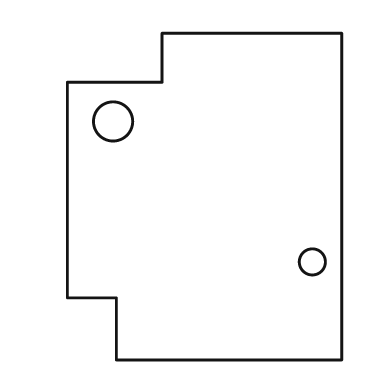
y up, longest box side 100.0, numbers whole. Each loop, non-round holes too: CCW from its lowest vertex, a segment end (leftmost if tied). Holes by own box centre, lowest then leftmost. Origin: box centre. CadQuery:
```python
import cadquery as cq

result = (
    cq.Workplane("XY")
    .moveTo(-27.0, -50.0)
    .lineTo(42.0, -50.0)
    .lineTo(42.0, 50.0)
    .lineTo(-13.0, 50.0)
    .lineTo(-13.0, 35.0)
    .lineTo(-42.0, 35.0)
    .lineTo(-42.0, -31.0)
    .lineTo(-27.0, -31.0)
    .close()
    .moveTo(33.0, -20.0)
    .circle(4.0)
    .moveTo(-28.0, 23.0)
    .circle(6.0)
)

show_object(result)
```